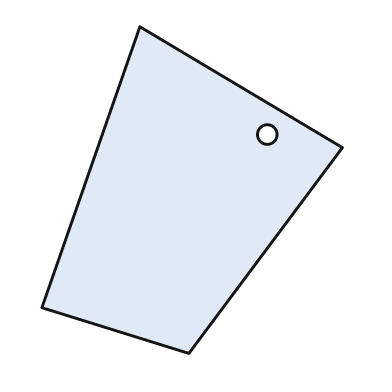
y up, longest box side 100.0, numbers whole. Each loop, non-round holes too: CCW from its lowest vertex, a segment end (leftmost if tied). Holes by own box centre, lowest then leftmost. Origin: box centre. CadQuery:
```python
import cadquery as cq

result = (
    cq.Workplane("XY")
    .moveTo(-1.0, -50.0)
    .lineTo(46.0, 13.0)
    .lineTo(-16.0, 50.0)
    .lineTo(-46.0, -36.0)
    .close()
    .moveTo(23.0, 17.0)
    .circle(3.0)
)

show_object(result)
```